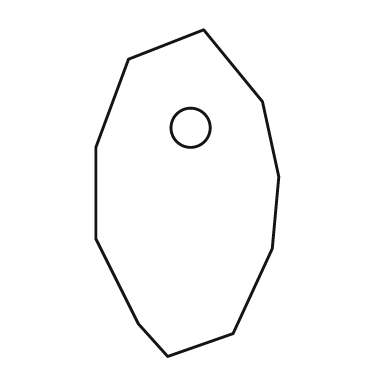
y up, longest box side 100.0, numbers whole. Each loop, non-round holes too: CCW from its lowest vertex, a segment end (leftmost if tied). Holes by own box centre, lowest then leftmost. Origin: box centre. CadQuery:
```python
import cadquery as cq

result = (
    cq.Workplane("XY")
    .moveTo(-6.0, -50.0)
    .lineTo(14.0, -43.0)
    .lineTo(26.0, -17.0)
    .lineTo(28.0, 5.0)
    .lineTo(23.0, 28.0)
    .lineTo(5.0, 50.0)
    .lineTo(-18.0, 41.0)
    .lineTo(-28.0, 14.0)
    .lineTo(-28.0, -14.0)
    .lineTo(-15.0, -40.0)
    .close()
    .moveTo(1.0, 20.0)
    .circle(6.0)
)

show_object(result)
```